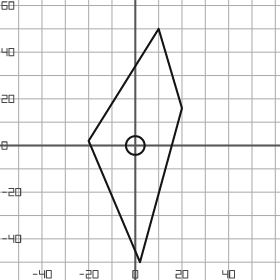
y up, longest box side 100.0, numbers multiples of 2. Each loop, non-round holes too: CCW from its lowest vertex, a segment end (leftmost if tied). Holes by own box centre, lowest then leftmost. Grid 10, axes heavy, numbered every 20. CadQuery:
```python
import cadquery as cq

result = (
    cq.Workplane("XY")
    .moveTo(2.0, -50.0)
    .lineTo(20.0, 16.0)
    .lineTo(10.0, 50.0)
    .lineTo(-20.0, 2.0)
    .close()
    .moveTo(0.0, 0.0)
    .circle(4.0)
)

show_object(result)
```